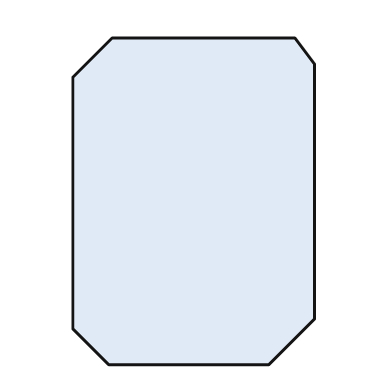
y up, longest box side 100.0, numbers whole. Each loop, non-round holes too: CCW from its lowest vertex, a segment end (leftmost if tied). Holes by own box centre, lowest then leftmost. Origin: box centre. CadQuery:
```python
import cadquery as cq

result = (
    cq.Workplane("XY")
    .moveTo(-26.0, -50.0)
    .lineTo(23.0, -50.0)
    .lineTo(37.0, -36.0)
    .lineTo(37.0, 42.0)
    .lineTo(31.0, 50.0)
    .lineTo(-25.0, 50.0)
    .lineTo(-37.0, 38.0)
    .lineTo(-37.0, -39.0)
    .close()
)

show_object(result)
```